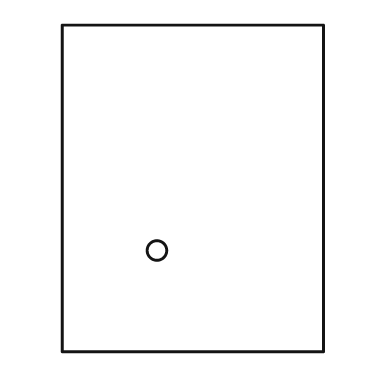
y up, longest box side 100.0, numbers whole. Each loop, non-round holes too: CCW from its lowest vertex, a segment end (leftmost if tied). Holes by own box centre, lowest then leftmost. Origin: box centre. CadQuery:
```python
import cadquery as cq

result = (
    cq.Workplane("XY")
    .moveTo(-40.0, -50.0)
    .lineTo(40.0, -50.0)
    .lineTo(40.0, 50.0)
    .lineTo(-40.0, 50.0)
    .close()
    .moveTo(-11.0, -19.0)
    .circle(3.0)
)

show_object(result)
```